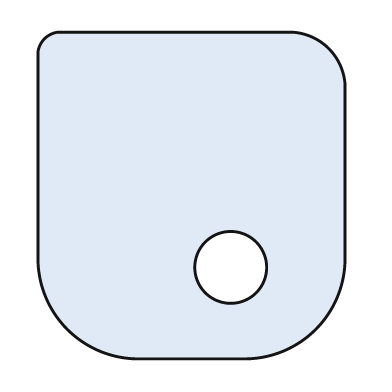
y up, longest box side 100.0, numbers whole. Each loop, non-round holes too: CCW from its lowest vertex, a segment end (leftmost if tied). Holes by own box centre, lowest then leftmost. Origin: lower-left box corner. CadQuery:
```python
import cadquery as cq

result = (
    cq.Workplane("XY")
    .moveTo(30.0, 0.0)
    .lineTo(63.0, 0.0)
    .threePointArc((85.0, 9.0), (94.0, 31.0))
    .lineTo(94.0, 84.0)
    .threePointArc((89.0, 95.0), (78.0, 100.0))
    .lineTo(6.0, 100.0)
    .threePointArc((2.0, 98.0), (0.0, 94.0))
    .lineTo(0.0, 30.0)
    .threePointArc((9.0, 9.0), (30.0, 0.0))
    .close()
    .moveTo(59.0, 28.0)
    .circle(11.0)
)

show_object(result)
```